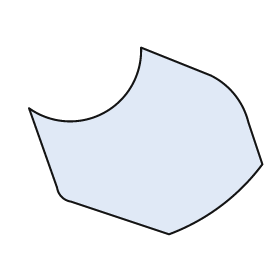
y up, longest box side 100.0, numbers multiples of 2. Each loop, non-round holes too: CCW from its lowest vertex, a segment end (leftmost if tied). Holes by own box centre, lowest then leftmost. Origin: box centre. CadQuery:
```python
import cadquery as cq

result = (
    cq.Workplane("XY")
    .moveTo(10.0, -40.0)
    .threePointArc((32.0, -28.0), (50.0, -10.0))
    .lineTo(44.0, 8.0)
    .threePointArc((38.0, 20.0), (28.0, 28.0))
    .lineTo(-2.0, 40.0)
    .threePointArc((-18.0, 12.0), (-50.0, 14.0))
    .lineTo(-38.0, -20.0)
    .threePointArc((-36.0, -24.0), (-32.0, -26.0))
    .close()
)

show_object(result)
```